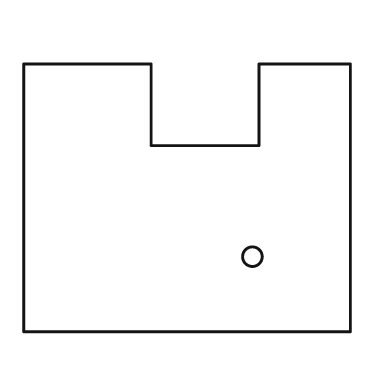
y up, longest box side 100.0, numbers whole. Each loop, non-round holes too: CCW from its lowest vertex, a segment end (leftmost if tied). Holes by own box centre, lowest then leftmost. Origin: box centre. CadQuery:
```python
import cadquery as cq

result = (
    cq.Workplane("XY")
    .moveTo(-50.0, -41.0)
    .lineTo(50.0, -41.0)
    .lineTo(50.0, 41.0)
    .lineTo(22.0, 41.0)
    .lineTo(22.0, 16.0)
    .lineTo(-11.0, 16.0)
    .lineTo(-11.0, 41.0)
    .lineTo(-50.0, 41.0)
    .close()
    .moveTo(20.0, -18.0)
    .circle(3.0)
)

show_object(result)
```